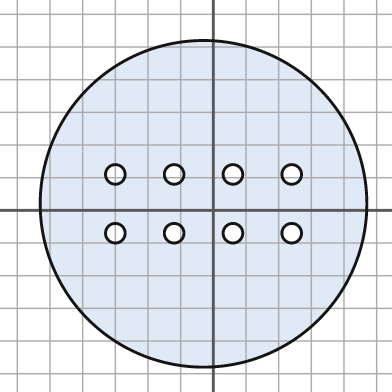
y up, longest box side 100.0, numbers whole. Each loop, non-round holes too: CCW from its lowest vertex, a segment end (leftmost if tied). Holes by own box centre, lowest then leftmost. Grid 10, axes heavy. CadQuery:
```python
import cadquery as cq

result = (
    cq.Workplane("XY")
    .moveTo(-3.0, 2.0)
    .circle(50.0)
    .moveTo(-30.0, -7.0)
    .circle(3.0)
    .moveTo(-12.0, -7.0)
    .circle(3.0)
    .moveTo(6.0, -7.0)
    .circle(3.0)
    .moveTo(24.0, -7.0)
    .circle(3.0)
    .moveTo(-30.0, 11.0)
    .circle(3.0)
    .moveTo(-12.0, 11.0)
    .circle(3.0)
    .moveTo(6.0, 11.0)
    .circle(3.0)
    .moveTo(24.0, 11.0)
    .circle(3.0)
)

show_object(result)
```